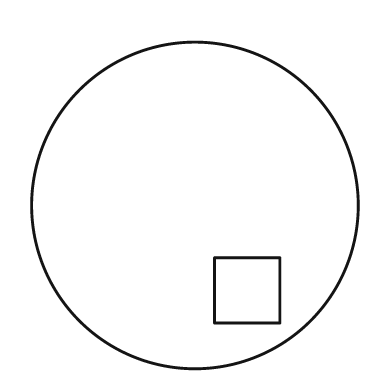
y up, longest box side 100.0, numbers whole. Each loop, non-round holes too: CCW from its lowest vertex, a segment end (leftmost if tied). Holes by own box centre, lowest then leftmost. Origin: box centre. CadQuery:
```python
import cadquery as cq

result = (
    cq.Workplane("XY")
    .moveTo(0.0, 0.0)
    .circle(50.0)
    .moveTo(6.0, -36.0)
    .lineTo(26.0, -36.0)
    .lineTo(26.0, -16.0)
    .lineTo(6.0, -16.0)
    .close()
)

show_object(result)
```